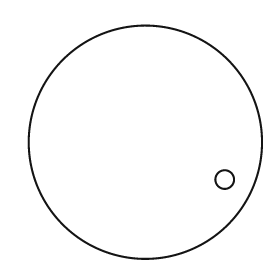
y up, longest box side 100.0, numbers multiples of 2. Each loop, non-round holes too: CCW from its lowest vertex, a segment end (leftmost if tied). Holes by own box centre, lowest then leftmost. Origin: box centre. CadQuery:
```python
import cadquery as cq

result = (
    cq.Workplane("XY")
    .moveTo(0.0, 0.0)
    .circle(50.0)
    .moveTo(34.0, -16.0)
    .circle(4.0)
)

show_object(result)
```